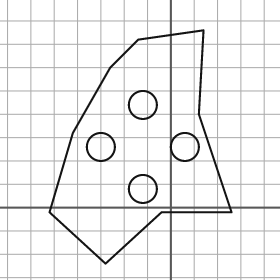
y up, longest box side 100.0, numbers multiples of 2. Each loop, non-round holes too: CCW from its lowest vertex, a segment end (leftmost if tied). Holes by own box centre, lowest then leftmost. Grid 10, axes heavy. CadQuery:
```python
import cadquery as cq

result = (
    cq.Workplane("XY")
    .moveTo(-28.0, -24.0)
    .lineTo(-4.0, -2.0)
    .lineTo(26.0, -2.0)
    .lineTo(12.0, 40.0)
    .lineTo(14.0, 76.0)
    .lineTo(-14.0, 72.0)
    .lineTo(-26.0, 60.0)
    .lineTo(-42.0, 32.0)
    .lineTo(-52.0, -2.0)
    .close()
    .moveTo(-12.0, 8.0)
    .circle(6.0)
    .moveTo(-30.0, 26.0)
    .circle(6.0)
    .moveTo(6.0, 26.0)
    .circle(6.0)
    .moveTo(-12.0, 44.0)
    .circle(6.0)
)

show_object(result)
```